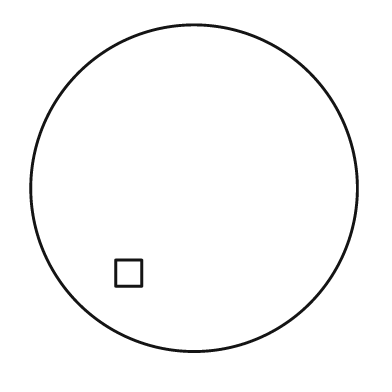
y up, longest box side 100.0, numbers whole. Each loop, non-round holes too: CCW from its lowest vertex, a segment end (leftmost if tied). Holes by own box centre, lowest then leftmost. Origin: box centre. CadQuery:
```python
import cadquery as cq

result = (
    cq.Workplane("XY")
    .moveTo(0.0, 0.0)
    .circle(50.0)
    .moveTo(-24.0, -30.0)
    .lineTo(-16.0, -30.0)
    .lineTo(-16.0, -22.0)
    .lineTo(-24.0, -22.0)
    .close()
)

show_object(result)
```